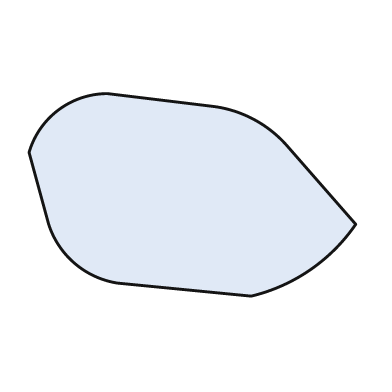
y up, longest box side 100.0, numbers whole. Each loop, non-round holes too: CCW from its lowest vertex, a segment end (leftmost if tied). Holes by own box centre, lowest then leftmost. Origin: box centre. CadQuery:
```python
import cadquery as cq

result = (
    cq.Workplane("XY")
    .moveTo(18.0, -31.0)
    .threePointArc((36.0, -23.0), (50.0, -9.0))
    .lineTo(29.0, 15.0)
    .threePointArc((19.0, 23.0), (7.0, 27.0))
    .lineTo(-26.0, 31.0)
    .threePointArc((-41.0, 26.0), (-50.0, 13.0))
    .lineTo(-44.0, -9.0)
    .threePointArc((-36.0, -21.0), (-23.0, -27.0))
    .close()
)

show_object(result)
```